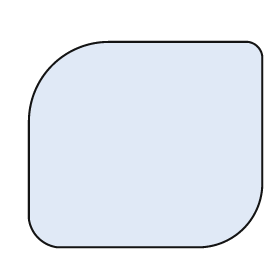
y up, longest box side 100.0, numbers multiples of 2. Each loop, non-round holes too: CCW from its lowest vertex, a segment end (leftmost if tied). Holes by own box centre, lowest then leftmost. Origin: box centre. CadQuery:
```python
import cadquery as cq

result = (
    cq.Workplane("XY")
    .moveTo(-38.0, -44.0)
    .lineTo(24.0, -44.0)
    .threePointArc((42.0, -36.0), (50.0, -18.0))
    .lineTo(50.0, 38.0)
    .threePointArc((48.0, 42.0), (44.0, 44.0))
    .lineTo(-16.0, 44.0)
    .threePointArc((-40.0, 34.0), (-50.0, 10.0))
    .lineTo(-50.0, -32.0)
    .threePointArc((-46.0, -40.0), (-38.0, -44.0))
    .close()
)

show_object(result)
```